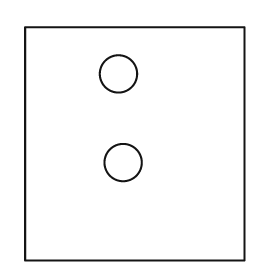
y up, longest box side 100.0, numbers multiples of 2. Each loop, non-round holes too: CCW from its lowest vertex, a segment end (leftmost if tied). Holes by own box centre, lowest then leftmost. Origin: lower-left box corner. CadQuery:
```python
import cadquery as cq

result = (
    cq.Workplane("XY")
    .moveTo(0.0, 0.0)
    .lineTo(94.0, 0.0)
    .lineTo(94.0, 100.0)
    .lineTo(0.0, 100.0)
    .close()
    .moveTo(42.0, 42.0)
    .circle(8.0)
    .moveTo(40.0, 80.0)
    .circle(8.0)
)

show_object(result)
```